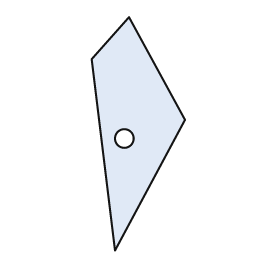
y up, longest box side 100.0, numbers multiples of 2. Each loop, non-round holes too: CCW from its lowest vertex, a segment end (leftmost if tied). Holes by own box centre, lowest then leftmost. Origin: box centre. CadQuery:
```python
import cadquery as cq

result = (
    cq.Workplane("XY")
    .moveTo(-10.0, -50.0)
    .lineTo(20.0, 6.0)
    .lineTo(-4.0, 50.0)
    .lineTo(-20.0, 32.0)
    .close()
    .moveTo(-6.0, -2.0)
    .circle(4.0)
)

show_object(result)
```